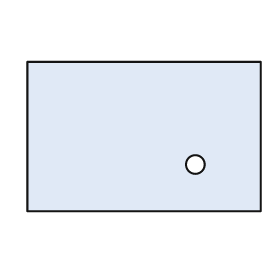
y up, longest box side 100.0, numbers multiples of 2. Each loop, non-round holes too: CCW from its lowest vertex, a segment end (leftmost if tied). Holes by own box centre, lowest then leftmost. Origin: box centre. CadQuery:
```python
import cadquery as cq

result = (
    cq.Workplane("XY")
    .moveTo(-50.0, -32.0)
    .lineTo(50.0, -32.0)
    .lineTo(50.0, 32.0)
    .lineTo(-50.0, 32.0)
    .close()
    .moveTo(22.0, -12.0)
    .circle(4.0)
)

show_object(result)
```